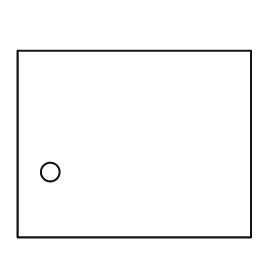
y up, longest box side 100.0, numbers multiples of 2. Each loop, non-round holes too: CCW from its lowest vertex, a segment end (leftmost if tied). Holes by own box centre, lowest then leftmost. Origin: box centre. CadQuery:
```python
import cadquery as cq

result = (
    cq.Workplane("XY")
    .moveTo(-50.0, -40.0)
    .lineTo(50.0, -40.0)
    .lineTo(50.0, 40.0)
    .lineTo(-50.0, 40.0)
    .close()
    .moveTo(-36.0, -12.0)
    .circle(4.0)
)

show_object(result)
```